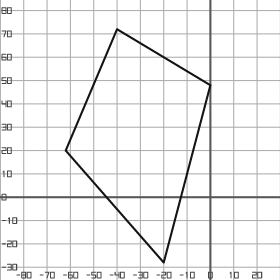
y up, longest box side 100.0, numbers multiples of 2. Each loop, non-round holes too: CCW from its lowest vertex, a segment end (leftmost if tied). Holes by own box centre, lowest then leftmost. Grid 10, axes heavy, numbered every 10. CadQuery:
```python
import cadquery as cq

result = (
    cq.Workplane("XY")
    .moveTo(-20.0, -28.0)
    .lineTo(0.0, 48.0)
    .lineTo(-40.0, 72.0)
    .lineTo(-62.0, 20.0)
    .close()
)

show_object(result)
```